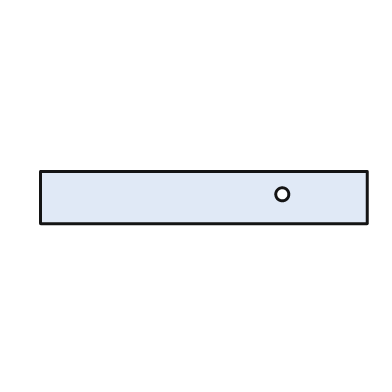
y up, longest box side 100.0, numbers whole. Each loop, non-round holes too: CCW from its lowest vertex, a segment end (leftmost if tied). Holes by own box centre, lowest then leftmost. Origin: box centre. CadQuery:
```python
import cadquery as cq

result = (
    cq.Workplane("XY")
    .moveTo(-50.0, -8.0)
    .lineTo(50.0, -8.0)
    .lineTo(50.0, 8.0)
    .lineTo(-50.0, 8.0)
    .close()
    .moveTo(24.0, 1.0)
    .circle(2.0)
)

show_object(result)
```